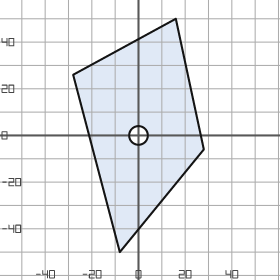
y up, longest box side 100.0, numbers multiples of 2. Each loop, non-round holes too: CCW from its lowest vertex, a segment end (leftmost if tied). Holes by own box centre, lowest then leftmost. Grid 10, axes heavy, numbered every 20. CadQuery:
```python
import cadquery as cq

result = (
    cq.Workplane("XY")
    .moveTo(-8.0, -50.0)
    .lineTo(28.0, -6.0)
    .lineTo(16.0, 50.0)
    .lineTo(-28.0, 26.0)
    .close()
    .moveTo(0.0, 0.0)
    .circle(4.0)
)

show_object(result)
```